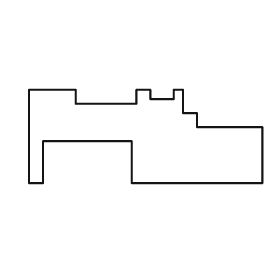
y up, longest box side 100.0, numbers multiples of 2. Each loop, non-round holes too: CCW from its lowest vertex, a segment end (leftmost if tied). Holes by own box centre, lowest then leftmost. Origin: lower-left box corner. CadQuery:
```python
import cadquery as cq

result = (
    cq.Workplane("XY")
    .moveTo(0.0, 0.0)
    .lineTo(6.0, 0.0)
    .lineTo(6.0, 18.0)
    .lineTo(44.0, 18.0)
    .lineTo(44.0, 0.0)
    .lineTo(100.0, 0.0)
    .lineTo(100.0, 24.0)
    .lineTo(72.0, 24.0)
    .lineTo(72.0, 30.0)
    .lineTo(66.0, 30.0)
    .lineTo(66.0, 40.0)
    .lineTo(62.0, 40.0)
    .lineTo(62.0, 36.0)
    .lineTo(52.0, 36.0)
    .lineTo(52.0, 40.0)
    .lineTo(46.0, 40.0)
    .lineTo(46.0, 34.0)
    .lineTo(20.0, 34.0)
    .lineTo(20.0, 40.0)
    .lineTo(0.0, 40.0)
    .close()
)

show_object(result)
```